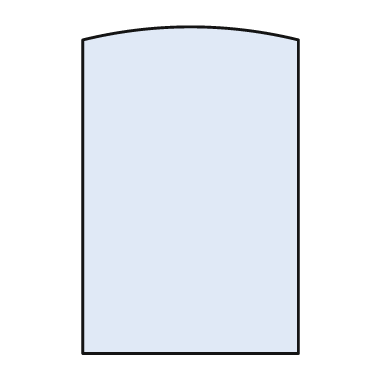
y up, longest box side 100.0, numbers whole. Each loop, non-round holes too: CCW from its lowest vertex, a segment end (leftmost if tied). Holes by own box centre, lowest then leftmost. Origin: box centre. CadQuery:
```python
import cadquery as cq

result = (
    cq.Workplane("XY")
    .moveTo(-33.0, -50.0)
    .lineTo(33.0, -50.0)
    .lineTo(33.0, 46.0)
    .threePointArc((0.0, 50.0), (-33.0, 46.0))
    .close()
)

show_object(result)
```